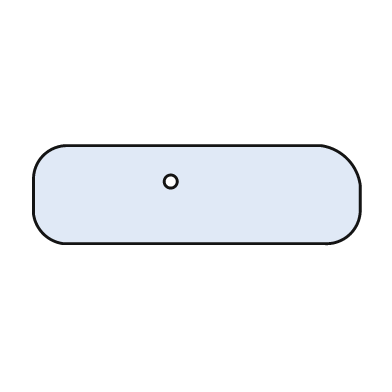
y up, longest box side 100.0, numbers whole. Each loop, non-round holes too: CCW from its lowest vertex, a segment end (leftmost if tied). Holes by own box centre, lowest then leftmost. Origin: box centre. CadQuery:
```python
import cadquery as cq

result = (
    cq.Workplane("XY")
    .moveTo(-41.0, -15.0)
    .lineTo(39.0, -15.0)
    .threePointArc((47.0, -12.0), (50.0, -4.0))
    .lineTo(50.0, 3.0)
    .threePointArc((46.0, 11.0), (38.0, 15.0))
    .lineTo(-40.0, 15.0)
    .threePointArc((-47.0, 12.0), (-50.0, 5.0))
    .lineTo(-50.0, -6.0)
    .threePointArc((-47.0, -12.0), (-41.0, -15.0))
    .close()
    .moveTo(-8.0, 4.0)
    .circle(2.0)
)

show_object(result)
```